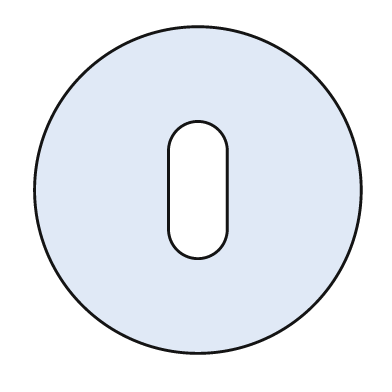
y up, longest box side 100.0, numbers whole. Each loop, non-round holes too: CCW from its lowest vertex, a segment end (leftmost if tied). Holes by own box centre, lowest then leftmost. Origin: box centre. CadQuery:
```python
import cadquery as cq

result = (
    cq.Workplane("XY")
    .moveTo(0.0, 0.0)
    .circle(50.0)
    .moveTo(-9.0, -12.0)
    .threePointArc((0.0, -21.0), (9.0, -12.0))
    .lineTo(9.0, 12.0)
    .threePointArc((0.0, 21.0), (-9.0, 12.0))
    .close()
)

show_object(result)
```